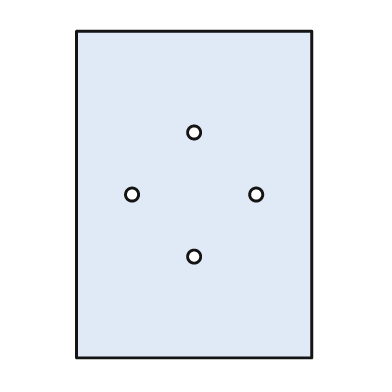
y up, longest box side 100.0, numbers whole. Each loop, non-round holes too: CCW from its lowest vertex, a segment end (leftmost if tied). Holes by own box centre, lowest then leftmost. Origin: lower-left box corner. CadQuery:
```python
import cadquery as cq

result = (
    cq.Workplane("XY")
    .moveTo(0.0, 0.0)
    .lineTo(72.0, 0.0)
    .lineTo(72.0, 100.0)
    .lineTo(0.0, 100.0)
    .close()
    .moveTo(36.0, 31.0)
    .circle(2.0)
    .moveTo(17.0, 50.0)
    .circle(2.0)
    .moveTo(55.0, 50.0)
    .circle(2.0)
    .moveTo(36.0, 69.0)
    .circle(2.0)
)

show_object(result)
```